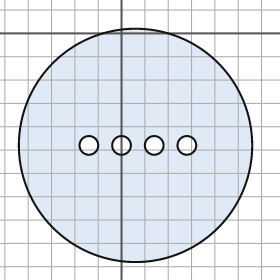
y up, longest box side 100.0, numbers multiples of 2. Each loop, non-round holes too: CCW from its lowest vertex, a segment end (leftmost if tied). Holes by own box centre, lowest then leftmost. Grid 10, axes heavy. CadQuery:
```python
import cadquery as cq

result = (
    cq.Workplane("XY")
    .moveTo(6.0, -48.0)
    .circle(50.0)
    .moveTo(-14.0, -48.0)
    .circle(4.0)
    .moveTo(0.0, -48.0)
    .circle(4.0)
    .moveTo(14.0, -48.0)
    .circle(4.0)
    .moveTo(28.0, -48.0)
    .circle(4.0)
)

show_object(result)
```